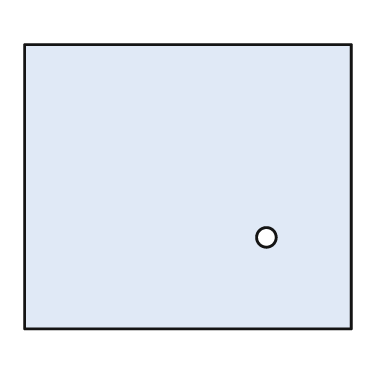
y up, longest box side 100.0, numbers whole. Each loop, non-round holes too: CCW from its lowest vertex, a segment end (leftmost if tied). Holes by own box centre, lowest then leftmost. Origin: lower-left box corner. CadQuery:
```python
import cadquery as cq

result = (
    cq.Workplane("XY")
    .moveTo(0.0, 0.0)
    .lineTo(100.0, 0.0)
    .lineTo(100.0, 87.0)
    .lineTo(0.0, 87.0)
    .close()
    .moveTo(74.0, 28.0)
    .circle(3.0)
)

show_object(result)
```